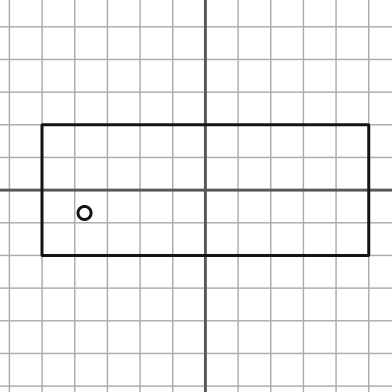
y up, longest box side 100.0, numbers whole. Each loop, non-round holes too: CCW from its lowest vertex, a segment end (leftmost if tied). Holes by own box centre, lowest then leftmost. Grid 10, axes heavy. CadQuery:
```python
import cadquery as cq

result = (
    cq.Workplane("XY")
    .moveTo(-50.0, -20.0)
    .lineTo(50.0, -20.0)
    .lineTo(50.0, 20.0)
    .lineTo(-50.0, 20.0)
    .close()
    .moveTo(-37.0, -7.0)
    .circle(2.0)
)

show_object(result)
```